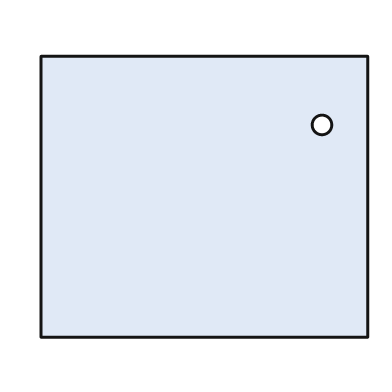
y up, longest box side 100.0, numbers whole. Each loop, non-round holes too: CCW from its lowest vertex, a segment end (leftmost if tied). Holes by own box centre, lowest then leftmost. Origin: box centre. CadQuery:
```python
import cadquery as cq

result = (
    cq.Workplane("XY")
    .moveTo(-50.0, -43.0)
    .lineTo(50.0, -43.0)
    .lineTo(50.0, 43.0)
    .lineTo(-50.0, 43.0)
    .close()
    .moveTo(36.0, 22.0)
    .circle(3.0)
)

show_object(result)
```